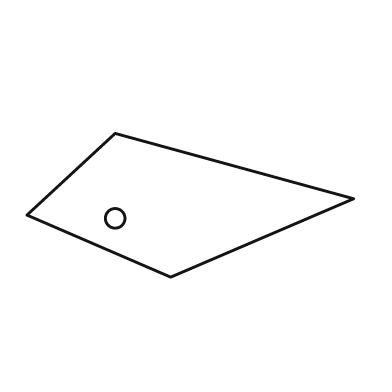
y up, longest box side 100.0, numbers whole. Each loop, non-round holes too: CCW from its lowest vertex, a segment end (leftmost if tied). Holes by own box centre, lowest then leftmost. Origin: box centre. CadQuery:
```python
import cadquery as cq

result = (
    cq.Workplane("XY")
    .moveTo(-6.0, -22.0)
    .lineTo(50.0, 2.0)
    .lineTo(-23.0, 22.0)
    .lineTo(-50.0, -3.0)
    .close()
    .moveTo(-23.0, -4.0)
    .circle(3.0)
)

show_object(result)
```